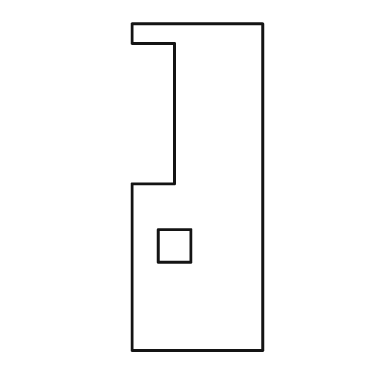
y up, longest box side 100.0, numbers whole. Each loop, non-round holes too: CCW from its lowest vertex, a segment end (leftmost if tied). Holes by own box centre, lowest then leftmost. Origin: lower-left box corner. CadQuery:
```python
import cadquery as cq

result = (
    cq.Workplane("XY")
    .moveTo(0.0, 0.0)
    .lineTo(40.0, 0.0)
    .lineTo(40.0, 100.0)
    .lineTo(0.0, 100.0)
    .lineTo(0.0, 94.0)
    .lineTo(13.0, 94.0)
    .lineTo(13.0, 51.0)
    .lineTo(0.0, 51.0)
    .close()
    .moveTo(8.0, 27.0)
    .lineTo(18.0, 27.0)
    .lineTo(18.0, 37.0)
    .lineTo(8.0, 37.0)
    .close()
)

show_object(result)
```